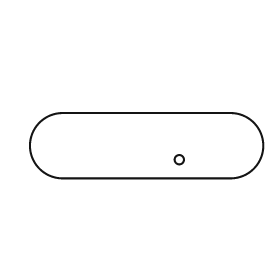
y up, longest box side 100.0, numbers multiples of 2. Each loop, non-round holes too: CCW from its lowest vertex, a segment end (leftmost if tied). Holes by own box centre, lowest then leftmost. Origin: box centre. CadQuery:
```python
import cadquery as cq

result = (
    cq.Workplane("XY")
    .moveTo(-36.0, -14.0)
    .lineTo(36.0, -14.0)
    .threePointArc((50.0, 0.0), (36.0, 14.0))
    .lineTo(-36.0, 14.0)
    .threePointArc((-50.0, 0.0), (-36.0, -14.0))
    .close()
    .moveTo(14.0, -6.0)
    .circle(2.0)
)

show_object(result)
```